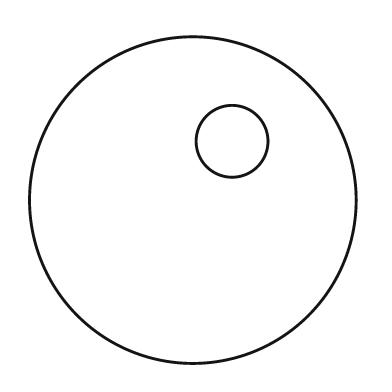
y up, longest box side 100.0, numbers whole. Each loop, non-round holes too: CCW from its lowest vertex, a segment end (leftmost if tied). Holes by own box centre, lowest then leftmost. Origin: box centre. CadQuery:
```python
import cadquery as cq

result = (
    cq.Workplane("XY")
    .moveTo(0.0, 0.0)
    .circle(50.0)
    .moveTo(12.0, 18.0)
    .circle(11.0)
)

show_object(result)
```